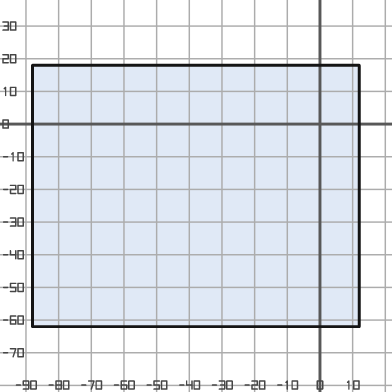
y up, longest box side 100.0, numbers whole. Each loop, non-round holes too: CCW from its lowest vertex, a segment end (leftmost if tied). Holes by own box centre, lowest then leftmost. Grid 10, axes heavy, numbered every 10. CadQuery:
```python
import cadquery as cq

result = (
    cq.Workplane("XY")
    .moveTo(-88.0, -62.0)
    .lineTo(12.0, -62.0)
    .lineTo(12.0, 18.0)
    .lineTo(-88.0, 18.0)
    .close()
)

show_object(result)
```